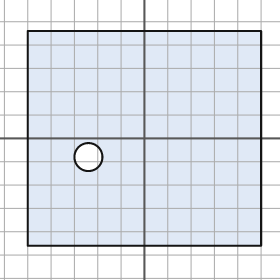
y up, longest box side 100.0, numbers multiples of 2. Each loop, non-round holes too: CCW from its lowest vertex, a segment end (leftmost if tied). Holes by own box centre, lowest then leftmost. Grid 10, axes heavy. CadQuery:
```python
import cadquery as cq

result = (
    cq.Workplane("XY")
    .moveTo(-50.0, -46.0)
    .lineTo(50.0, -46.0)
    .lineTo(50.0, 46.0)
    .lineTo(-50.0, 46.0)
    .close()
    .moveTo(-24.0, -8.0)
    .circle(6.0)
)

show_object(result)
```